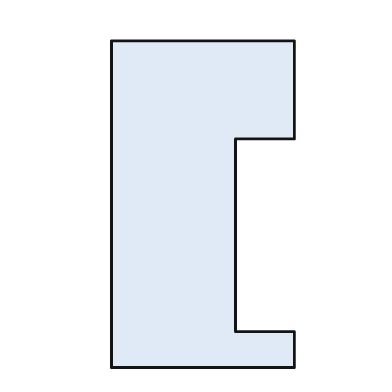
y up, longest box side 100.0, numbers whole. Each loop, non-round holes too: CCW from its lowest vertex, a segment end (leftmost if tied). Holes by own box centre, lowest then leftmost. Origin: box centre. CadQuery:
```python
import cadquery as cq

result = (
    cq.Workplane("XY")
    .moveTo(-28.0, -50.0)
    .lineTo(28.0, -50.0)
    .lineTo(28.0, -39.0)
    .lineTo(10.0, -39.0)
    .lineTo(10.0, 20.0)
    .lineTo(28.0, 20.0)
    .lineTo(28.0, 50.0)
    .lineTo(-28.0, 50.0)
    .close()
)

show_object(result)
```